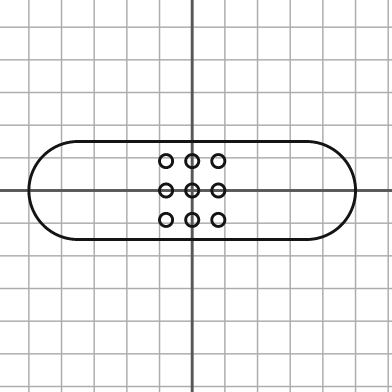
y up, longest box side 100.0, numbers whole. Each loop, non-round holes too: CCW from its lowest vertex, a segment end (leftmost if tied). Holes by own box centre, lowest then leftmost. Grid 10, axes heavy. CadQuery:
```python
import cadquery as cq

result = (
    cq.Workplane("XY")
    .moveTo(-35.0, -15.0)
    .lineTo(35.0, -15.0)
    .threePointArc((50.0, 0.0), (35.0, 15.0))
    .lineTo(-35.0, 15.0)
    .threePointArc((-50.0, 0.0), (-35.0, -15.0))
    .close()
    .moveTo(-8.0, -9.0)
    .circle(2.0)
    .moveTo(0.0, -9.0)
    .circle(2.0)
    .moveTo(8.0, -9.0)
    .circle(2.0)
    .moveTo(-8.0, 0.0)
    .circle(2.0)
    .moveTo(0.0, 0.0)
    .circle(2.0)
    .moveTo(8.0, 0.0)
    .circle(2.0)
    .moveTo(-8.0, 9.0)
    .circle(2.0)
    .moveTo(0.0, 9.0)
    .circle(2.0)
    .moveTo(8.0, 9.0)
    .circle(2.0)
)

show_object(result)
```